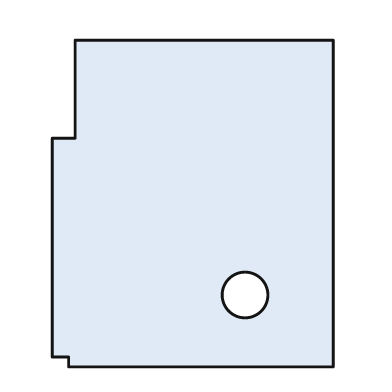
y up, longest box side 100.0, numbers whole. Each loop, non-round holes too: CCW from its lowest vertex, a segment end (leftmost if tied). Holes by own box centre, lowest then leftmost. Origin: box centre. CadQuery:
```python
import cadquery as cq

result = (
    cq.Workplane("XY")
    .moveTo(-38.0, -50.0)
    .lineTo(43.0, -50.0)
    .lineTo(43.0, 50.0)
    .lineTo(-36.0, 50.0)
    .lineTo(-36.0, 20.0)
    .lineTo(-43.0, 20.0)
    .lineTo(-43.0, -47.0)
    .lineTo(-38.0, -47.0)
    .close()
    .moveTo(16.0, -28.0)
    .circle(7.0)
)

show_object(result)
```